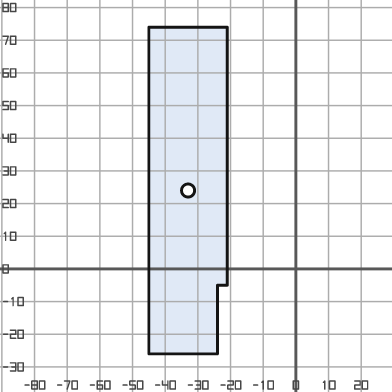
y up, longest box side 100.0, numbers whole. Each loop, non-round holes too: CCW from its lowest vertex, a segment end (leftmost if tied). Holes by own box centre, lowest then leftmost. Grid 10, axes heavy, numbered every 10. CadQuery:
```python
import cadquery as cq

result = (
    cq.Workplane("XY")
    .moveTo(-45.0, -26.0)
    .lineTo(-24.0, -26.0)
    .lineTo(-24.0, -5.0)
    .lineTo(-21.0, -5.0)
    .lineTo(-21.0, 74.0)
    .lineTo(-45.0, 74.0)
    .close()
    .moveTo(-33.0, 24.0)
    .circle(2.0)
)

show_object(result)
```